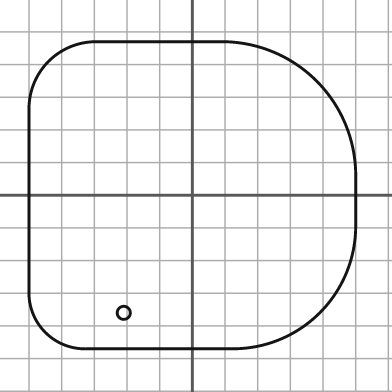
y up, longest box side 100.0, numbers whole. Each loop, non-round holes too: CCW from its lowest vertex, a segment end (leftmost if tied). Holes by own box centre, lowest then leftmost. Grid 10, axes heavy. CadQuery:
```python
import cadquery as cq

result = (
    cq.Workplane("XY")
    .moveTo(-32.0, -47.0)
    .lineTo(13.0, -47.0)
    .threePointArc((39.0, -36.0), (50.0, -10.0))
    .lineTo(50.0, 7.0)
    .threePointArc((38.0, 35.0), (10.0, 47.0))
    .lineTo(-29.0, 47.0)
    .threePointArc((-44.0, 41.0), (-50.0, 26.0))
    .lineTo(-50.0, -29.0)
    .threePointArc((-45.0, -42.0), (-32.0, -47.0))
    .close()
    .moveTo(-21.0, -36.0)
    .circle(2.0)
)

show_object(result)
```